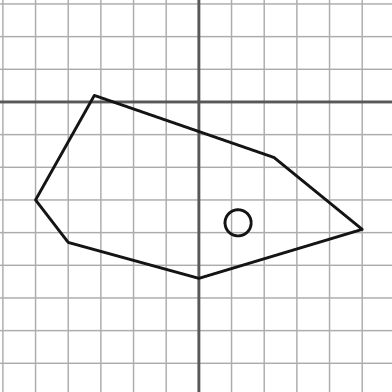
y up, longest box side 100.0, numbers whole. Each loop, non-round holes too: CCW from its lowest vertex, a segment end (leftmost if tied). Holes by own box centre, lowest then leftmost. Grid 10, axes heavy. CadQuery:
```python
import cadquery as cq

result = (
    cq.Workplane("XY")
    .moveTo(0.0, -54.0)
    .lineTo(50.0, -39.0)
    .lineTo(23.0, -17.0)
    .lineTo(-32.0, 2.0)
    .lineTo(-50.0, -30.0)
    .lineTo(-40.0, -43.0)
    .close()
    .moveTo(12.0, -37.0)
    .circle(4.0)
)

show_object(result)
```